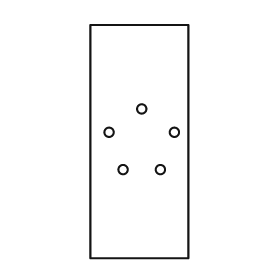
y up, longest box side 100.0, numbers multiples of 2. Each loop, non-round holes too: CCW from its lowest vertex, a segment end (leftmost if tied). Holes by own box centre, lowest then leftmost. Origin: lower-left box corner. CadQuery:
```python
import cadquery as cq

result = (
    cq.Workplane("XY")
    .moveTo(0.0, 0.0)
    .lineTo(42.0, 0.0)
    .lineTo(42.0, 100.0)
    .lineTo(0.0, 100.0)
    .close()
    .moveTo(14.0, 38.0)
    .circle(2.0)
    .moveTo(30.0, 38.0)
    .circle(2.0)
    .moveTo(8.0, 54.0)
    .circle(2.0)
    .moveTo(36.0, 54.0)
    .circle(2.0)
    .moveTo(22.0, 64.0)
    .circle(2.0)
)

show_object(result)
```